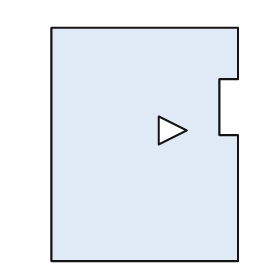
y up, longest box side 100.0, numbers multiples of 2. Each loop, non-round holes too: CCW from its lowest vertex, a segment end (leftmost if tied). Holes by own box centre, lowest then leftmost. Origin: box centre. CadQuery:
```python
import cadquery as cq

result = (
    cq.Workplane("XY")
    .moveTo(-40.0, -50.0)
    .lineTo(40.0, -50.0)
    .lineTo(40.0, 4.0)
    .lineTo(32.0, 4.0)
    .lineTo(32.0, 28.0)
    .lineTo(40.0, 28.0)
    .lineTo(40.0, 50.0)
    .lineTo(-40.0, 50.0)
    .close()
    .moveTo(6.0, 0.0)
    .lineTo(18.0, 6.0)
    .lineTo(6.0, 12.0)
    .close()
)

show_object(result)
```